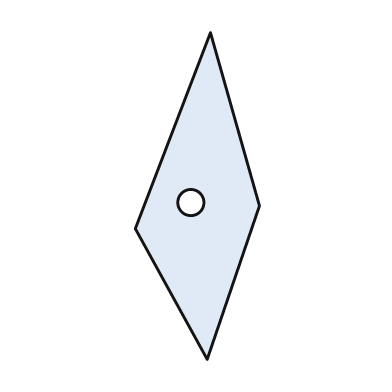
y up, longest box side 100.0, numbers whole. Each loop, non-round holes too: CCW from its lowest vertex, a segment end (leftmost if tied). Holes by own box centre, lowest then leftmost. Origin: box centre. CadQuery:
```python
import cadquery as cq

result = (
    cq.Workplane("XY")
    .moveTo(3.0, -50.0)
    .lineTo(19.0, -3.0)
    .lineTo(4.0, 50.0)
    .lineTo(-19.0, -10.0)
    .close()
    .moveTo(-2.0, -2.0)
    .circle(4.0)
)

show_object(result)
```